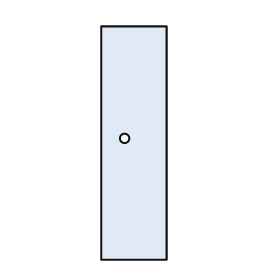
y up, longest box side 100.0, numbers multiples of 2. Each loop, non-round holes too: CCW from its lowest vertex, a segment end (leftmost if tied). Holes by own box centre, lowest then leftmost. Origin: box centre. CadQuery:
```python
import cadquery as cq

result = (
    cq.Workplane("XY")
    .moveTo(-14.0, -50.0)
    .lineTo(14.0, -50.0)
    .lineTo(14.0, 50.0)
    .lineTo(-14.0, 50.0)
    .close()
    .moveTo(-4.0, 2.0)
    .circle(2.0)
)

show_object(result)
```